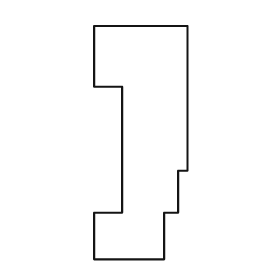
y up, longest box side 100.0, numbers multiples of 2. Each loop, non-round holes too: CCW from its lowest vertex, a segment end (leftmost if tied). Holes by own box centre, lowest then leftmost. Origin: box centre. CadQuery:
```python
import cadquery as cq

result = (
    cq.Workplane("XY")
    .moveTo(-20.0, -50.0)
    .lineTo(10.0, -50.0)
    .lineTo(10.0, -30.0)
    .lineTo(16.0, -30.0)
    .lineTo(16.0, -12.0)
    .lineTo(20.0, -12.0)
    .lineTo(20.0, 50.0)
    .lineTo(-20.0, 50.0)
    .lineTo(-20.0, 24.0)
    .lineTo(-8.0, 24.0)
    .lineTo(-8.0, -30.0)
    .lineTo(-20.0, -30.0)
    .close()
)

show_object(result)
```